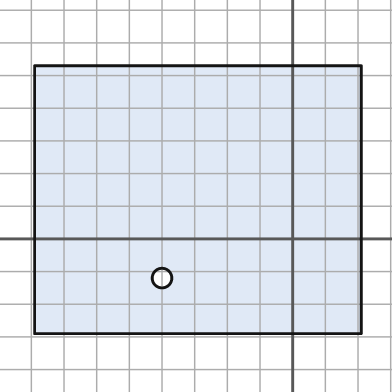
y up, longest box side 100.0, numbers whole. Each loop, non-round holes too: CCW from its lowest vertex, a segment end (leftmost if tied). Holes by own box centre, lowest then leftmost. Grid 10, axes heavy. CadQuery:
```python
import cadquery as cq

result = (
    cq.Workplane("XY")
    .moveTo(-79.0, -29.0)
    .lineTo(21.0, -29.0)
    .lineTo(21.0, 53.0)
    .lineTo(-79.0, 53.0)
    .close()
    .moveTo(-40.0, -12.0)
    .circle(3.0)
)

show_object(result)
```